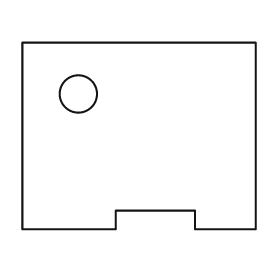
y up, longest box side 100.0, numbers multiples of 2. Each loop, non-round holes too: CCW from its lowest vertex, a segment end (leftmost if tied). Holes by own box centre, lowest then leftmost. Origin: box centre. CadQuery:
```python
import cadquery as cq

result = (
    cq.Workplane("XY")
    .moveTo(-50.0, -40.0)
    .lineTo(-10.0, -40.0)
    .lineTo(-10.0, -32.0)
    .lineTo(24.0, -32.0)
    .lineTo(24.0, -40.0)
    .lineTo(50.0, -40.0)
    .lineTo(50.0, 40.0)
    .lineTo(-50.0, 40.0)
    .close()
    .moveTo(-26.0, 18.0)
    .circle(8.0)
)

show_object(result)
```